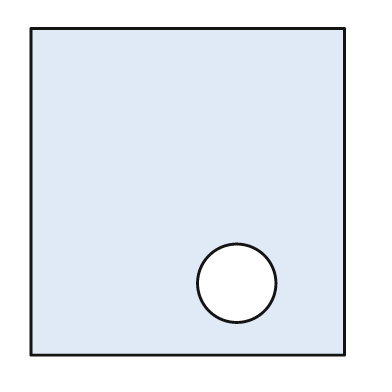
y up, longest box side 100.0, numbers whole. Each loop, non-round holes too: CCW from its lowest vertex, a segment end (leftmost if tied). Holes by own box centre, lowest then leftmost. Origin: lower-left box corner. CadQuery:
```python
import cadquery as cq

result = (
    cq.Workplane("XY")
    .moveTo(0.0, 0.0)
    .lineTo(96.0, 0.0)
    .lineTo(96.0, 100.0)
    .lineTo(0.0, 100.0)
    .close()
    .moveTo(63.0, 22.0)
    .circle(12.0)
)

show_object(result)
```